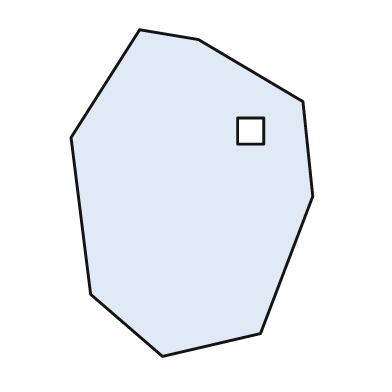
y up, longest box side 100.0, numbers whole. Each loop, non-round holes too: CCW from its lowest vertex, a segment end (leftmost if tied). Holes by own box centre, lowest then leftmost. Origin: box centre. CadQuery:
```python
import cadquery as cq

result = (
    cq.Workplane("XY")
    .moveTo(-9.0, -50.0)
    .lineTo(21.0, -43.0)
    .lineTo(37.0, -1.0)
    .lineTo(34.0, 28.0)
    .lineTo(2.0, 47.0)
    .lineTo(-16.0, 50.0)
    .lineTo(-37.0, 17.0)
    .lineTo(-31.0, -31.0)
    .close()
    .moveTo(14.0, 15.0)
    .lineTo(22.0, 15.0)
    .lineTo(22.0, 23.0)
    .lineTo(14.0, 23.0)
    .close()
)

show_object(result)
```